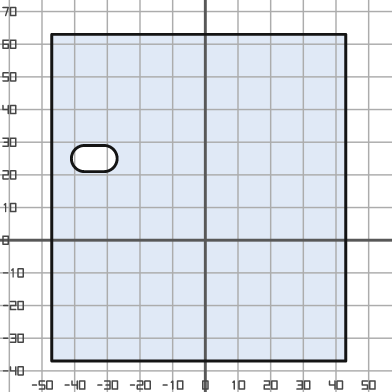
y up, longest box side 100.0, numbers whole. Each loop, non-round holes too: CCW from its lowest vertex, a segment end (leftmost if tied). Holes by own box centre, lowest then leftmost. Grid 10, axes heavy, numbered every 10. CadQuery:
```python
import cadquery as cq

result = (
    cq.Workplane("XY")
    .moveTo(-47.0, -37.0)
    .lineTo(43.0, -37.0)
    .lineTo(43.0, 63.0)
    .lineTo(-47.0, 63.0)
    .close()
    .moveTo(-37.0, 21.0)
    .lineTo(-31.0, 21.0)
    .threePointArc((-27.0, 25.0), (-31.0, 29.0))
    .lineTo(-37.0, 29.0)
    .threePointArc((-41.0, 25.0), (-37.0, 21.0))
    .close()
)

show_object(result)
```